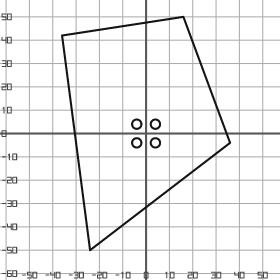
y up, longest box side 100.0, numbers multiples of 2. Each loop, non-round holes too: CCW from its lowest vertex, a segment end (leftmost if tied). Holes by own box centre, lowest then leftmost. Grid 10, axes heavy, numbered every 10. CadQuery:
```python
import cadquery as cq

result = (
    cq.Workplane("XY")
    .moveTo(-24.0, -50.0)
    .lineTo(36.0, -4.0)
    .lineTo(16.0, 50.0)
    .lineTo(-36.0, 42.0)
    .close()
    .moveTo(-4.0, -4.0)
    .circle(2.0)
    .moveTo(4.0, -4.0)
    .circle(2.0)
    .moveTo(-4.0, 4.0)
    .circle(2.0)
    .moveTo(4.0, 4.0)
    .circle(2.0)
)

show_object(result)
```